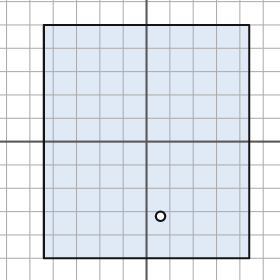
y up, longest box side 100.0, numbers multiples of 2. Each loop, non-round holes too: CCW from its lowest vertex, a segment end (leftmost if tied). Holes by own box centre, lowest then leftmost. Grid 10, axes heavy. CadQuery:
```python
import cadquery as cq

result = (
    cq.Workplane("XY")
    .moveTo(-44.0, -50.0)
    .lineTo(44.0, -50.0)
    .lineTo(44.0, 50.0)
    .lineTo(-44.0, 50.0)
    .close()
    .moveTo(6.0, -32.0)
    .circle(2.0)
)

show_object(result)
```